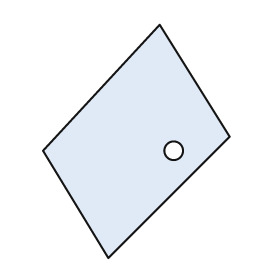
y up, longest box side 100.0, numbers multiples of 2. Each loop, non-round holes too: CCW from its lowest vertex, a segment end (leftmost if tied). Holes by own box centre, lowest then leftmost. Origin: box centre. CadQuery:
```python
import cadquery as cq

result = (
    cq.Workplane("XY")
    .moveTo(-12.0, -50.0)
    .lineTo(40.0, 2.0)
    .lineTo(10.0, 50.0)
    .lineTo(-40.0, -4.0)
    .close()
    .moveTo(16.0, -4.0)
    .circle(4.0)
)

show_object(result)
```